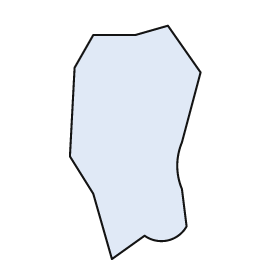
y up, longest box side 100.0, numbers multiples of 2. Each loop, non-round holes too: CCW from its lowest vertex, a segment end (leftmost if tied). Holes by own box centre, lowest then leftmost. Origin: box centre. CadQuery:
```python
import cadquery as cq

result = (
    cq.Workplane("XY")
    .moveTo(-10.0, -50.0)
    .lineTo(4.0, -40.0)
    .threePointArc((14.0, -42.0), (22.0, -36.0))
    .lineTo(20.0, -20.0)
    .threePointArc((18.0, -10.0), (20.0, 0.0))
    .lineTo(28.0, 30.0)
    .lineTo(14.0, 50.0)
    .lineTo(0.0, 46.0)
    .lineTo(-18.0, 46.0)
    .lineTo(-26.0, 32.0)
    .lineTo(-28.0, -6.0)
    .lineTo(-18.0, -22.0)
    .close()
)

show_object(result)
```